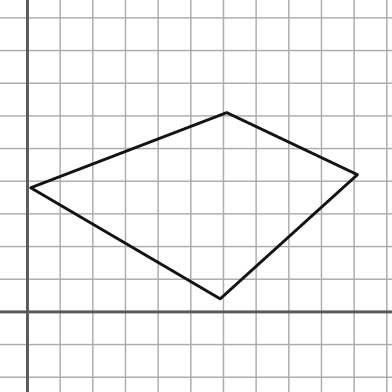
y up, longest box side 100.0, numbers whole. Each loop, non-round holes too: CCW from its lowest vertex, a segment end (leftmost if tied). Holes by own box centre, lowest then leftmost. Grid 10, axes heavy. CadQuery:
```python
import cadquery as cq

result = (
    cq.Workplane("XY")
    .moveTo(59.0, 4.0)
    .lineTo(101.0, 42.0)
    .lineTo(61.0, 61.0)
    .lineTo(1.0, 38.0)
    .close()
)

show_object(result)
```